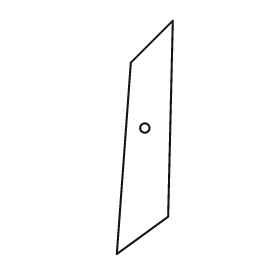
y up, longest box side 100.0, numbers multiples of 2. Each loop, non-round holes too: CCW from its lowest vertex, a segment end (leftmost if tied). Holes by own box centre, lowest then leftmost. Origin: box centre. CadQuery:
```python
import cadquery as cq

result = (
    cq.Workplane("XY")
    .moveTo(-12.0, -50.0)
    .lineTo(10.0, -34.0)
    .lineTo(12.0, 50.0)
    .lineTo(-6.0, 32.0)
    .close()
    .moveTo(0.0, 4.0)
    .circle(2.0)
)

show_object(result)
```